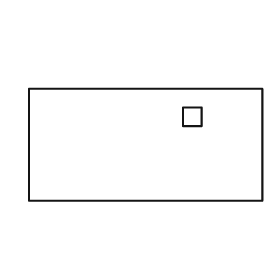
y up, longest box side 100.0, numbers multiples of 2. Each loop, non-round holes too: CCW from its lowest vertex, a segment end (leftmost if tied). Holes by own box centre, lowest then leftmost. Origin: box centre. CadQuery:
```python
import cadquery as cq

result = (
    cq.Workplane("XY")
    .moveTo(-50.0, -24.0)
    .lineTo(50.0, -24.0)
    .lineTo(50.0, 24.0)
    .lineTo(-50.0, 24.0)
    .close()
    .moveTo(16.0, 8.0)
    .lineTo(24.0, 8.0)
    .lineTo(24.0, 16.0)
    .lineTo(16.0, 16.0)
    .close()
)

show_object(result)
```